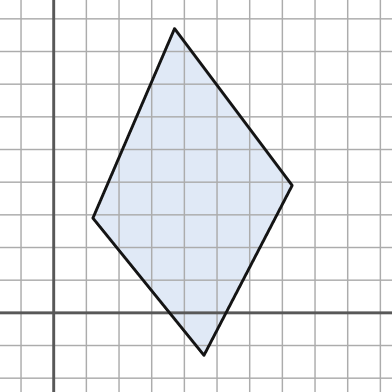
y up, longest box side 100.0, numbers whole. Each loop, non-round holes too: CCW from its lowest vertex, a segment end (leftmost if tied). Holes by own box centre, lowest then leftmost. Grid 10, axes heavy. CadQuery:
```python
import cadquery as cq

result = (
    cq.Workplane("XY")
    .moveTo(46.0, -13.0)
    .lineTo(73.0, 39.0)
    .lineTo(37.0, 87.0)
    .lineTo(12.0, 29.0)
    .close()
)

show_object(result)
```